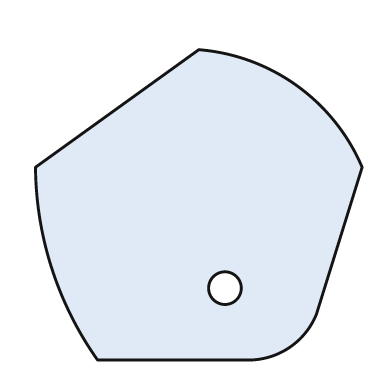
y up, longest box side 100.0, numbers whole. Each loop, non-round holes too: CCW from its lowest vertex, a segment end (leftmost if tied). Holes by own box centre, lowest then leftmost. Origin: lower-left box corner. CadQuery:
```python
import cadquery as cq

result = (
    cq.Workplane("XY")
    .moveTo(19.0, 0.0)
    .lineTo(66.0, 0.0)
    .threePointArc((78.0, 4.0), (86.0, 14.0))
    .lineTo(100.0, 59.0)
    .threePointArc((80.0, 84.0), (50.0, 95.0))
    .lineTo(0.0, 59.0)
    .threePointArc((5.0, 28.0), (19.0, 0.0))
    .close()
    .moveTo(58.0, 22.0)
    .circle(5.0)
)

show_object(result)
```